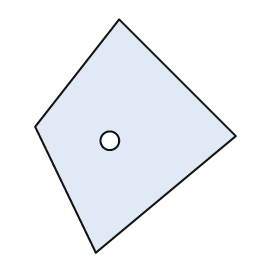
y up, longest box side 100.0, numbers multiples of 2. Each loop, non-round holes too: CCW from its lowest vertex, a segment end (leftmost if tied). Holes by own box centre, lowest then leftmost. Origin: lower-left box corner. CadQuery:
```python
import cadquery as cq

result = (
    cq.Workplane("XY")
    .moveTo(26.0, 0.0)
    .lineTo(86.0, 50.0)
    .lineTo(36.0, 100.0)
    .lineTo(0.0, 54.0)
    .close()
    .moveTo(32.0, 48.0)
    .circle(4.0)
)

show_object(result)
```